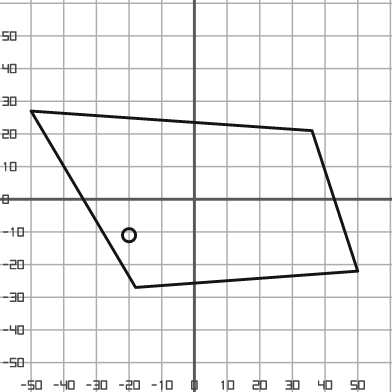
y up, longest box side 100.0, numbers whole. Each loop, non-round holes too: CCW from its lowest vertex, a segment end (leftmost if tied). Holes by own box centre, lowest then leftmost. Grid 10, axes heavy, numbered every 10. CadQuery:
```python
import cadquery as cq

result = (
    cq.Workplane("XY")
    .moveTo(-18.0, -27.0)
    .lineTo(50.0, -22.0)
    .lineTo(36.0, 21.0)
    .lineTo(-50.0, 27.0)
    .close()
    .moveTo(-20.0, -11.0)
    .circle(2.0)
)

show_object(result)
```